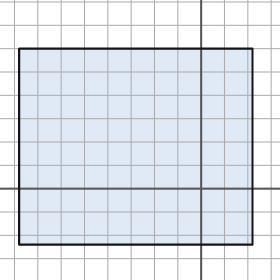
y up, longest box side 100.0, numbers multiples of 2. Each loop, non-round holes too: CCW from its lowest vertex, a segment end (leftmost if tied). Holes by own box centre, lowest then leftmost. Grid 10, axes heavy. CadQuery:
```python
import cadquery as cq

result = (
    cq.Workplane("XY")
    .moveTo(-78.0, -24.0)
    .lineTo(22.0, -24.0)
    .lineTo(22.0, 60.0)
    .lineTo(-78.0, 60.0)
    .close()
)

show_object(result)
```